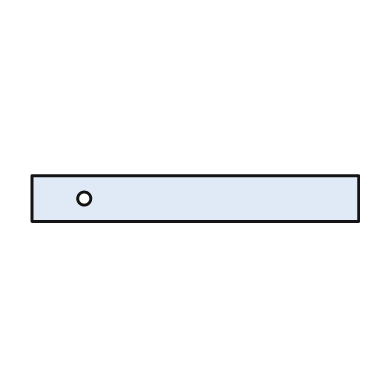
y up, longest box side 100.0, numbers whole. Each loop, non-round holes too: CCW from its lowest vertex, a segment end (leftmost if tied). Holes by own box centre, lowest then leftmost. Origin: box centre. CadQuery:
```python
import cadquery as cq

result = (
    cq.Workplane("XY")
    .moveTo(-50.0, -7.0)
    .lineTo(50.0, -7.0)
    .lineTo(50.0, 7.0)
    .lineTo(-50.0, 7.0)
    .close()
    .moveTo(-34.0, 0.0)
    .circle(2.0)
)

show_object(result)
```